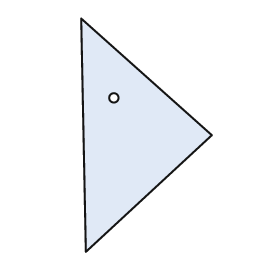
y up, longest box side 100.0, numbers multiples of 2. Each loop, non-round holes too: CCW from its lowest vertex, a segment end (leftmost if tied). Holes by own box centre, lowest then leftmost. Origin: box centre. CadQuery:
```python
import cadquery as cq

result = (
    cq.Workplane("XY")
    .moveTo(-26.0, -50.0)
    .lineTo(28.0, 0.0)
    .lineTo(-28.0, 50.0)
    .close()
    .moveTo(-14.0, 16.0)
    .circle(2.0)
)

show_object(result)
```